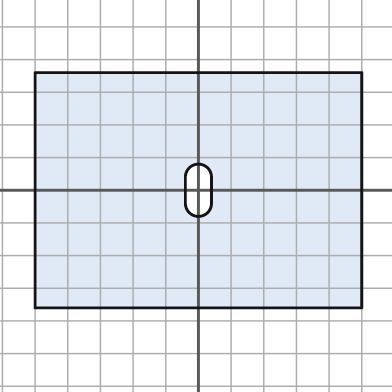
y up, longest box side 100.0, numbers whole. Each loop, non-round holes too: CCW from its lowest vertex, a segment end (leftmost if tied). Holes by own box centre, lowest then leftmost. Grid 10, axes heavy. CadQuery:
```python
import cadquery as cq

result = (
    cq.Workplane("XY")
    .moveTo(-50.0, -36.0)
    .lineTo(50.0, -36.0)
    .lineTo(50.0, 36.0)
    .lineTo(-50.0, 36.0)
    .close()
    .moveTo(-4.0, -4.0)
    .threePointArc((0.0, -8.0), (4.0, -4.0))
    .lineTo(4.0, 4.0)
    .threePointArc((0.0, 8.0), (-4.0, 4.0))
    .close()
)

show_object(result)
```